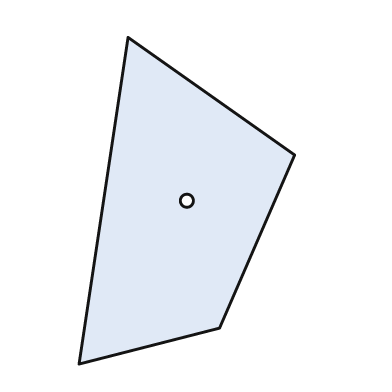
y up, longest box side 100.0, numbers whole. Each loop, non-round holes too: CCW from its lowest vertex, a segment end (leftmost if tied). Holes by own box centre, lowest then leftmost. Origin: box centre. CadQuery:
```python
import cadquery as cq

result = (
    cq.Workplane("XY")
    .moveTo(-33.0, -50.0)
    .lineTo(10.0, -39.0)
    .lineTo(33.0, 14.0)
    .lineTo(-18.0, 50.0)
    .close()
    .moveTo(0.0, 0.0)
    .circle(2.0)
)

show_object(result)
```